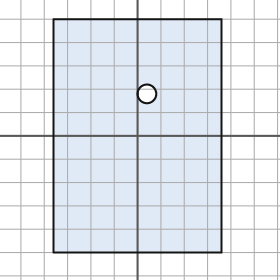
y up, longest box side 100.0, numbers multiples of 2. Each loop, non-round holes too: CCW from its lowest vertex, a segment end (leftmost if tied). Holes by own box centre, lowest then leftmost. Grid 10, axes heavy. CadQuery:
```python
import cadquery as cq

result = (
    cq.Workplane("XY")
    .moveTo(-36.0, -50.0)
    .lineTo(36.0, -50.0)
    .lineTo(36.0, 50.0)
    .lineTo(-36.0, 50.0)
    .close()
    .moveTo(4.0, 18.0)
    .circle(4.0)
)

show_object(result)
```